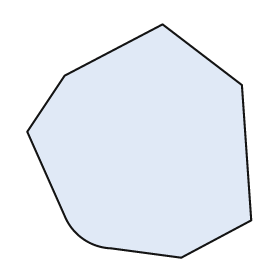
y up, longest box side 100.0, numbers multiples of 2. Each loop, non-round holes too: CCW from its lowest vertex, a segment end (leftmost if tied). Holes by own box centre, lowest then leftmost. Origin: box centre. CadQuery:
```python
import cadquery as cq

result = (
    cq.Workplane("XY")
    .moveTo(18.0, -50.0)
    .lineTo(48.0, -34.0)
    .lineTo(44.0, 24.0)
    .lineTo(10.0, 50.0)
    .lineTo(-32.0, 28.0)
    .lineTo(-48.0, 4.0)
    .lineTo(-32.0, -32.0)
    .threePointArc((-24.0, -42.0), (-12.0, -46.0))
    .close()
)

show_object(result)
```